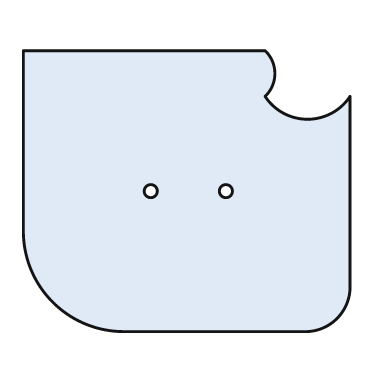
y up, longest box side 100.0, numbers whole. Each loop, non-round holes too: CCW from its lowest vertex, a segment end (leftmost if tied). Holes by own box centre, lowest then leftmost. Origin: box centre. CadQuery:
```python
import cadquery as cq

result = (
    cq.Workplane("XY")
    .moveTo(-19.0, -43.0)
    .lineTo(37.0, -43.0)
    .threePointArc((46.0, -39.0), (50.0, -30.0))
    .lineTo(50.0, 29.0)
    .threePointArc((37.0, 22.0), (24.0, 29.0))
    .threePointArc((27.0, 36.0), (24.0, 43.0))
    .lineTo(-50.0, 43.0)
    .lineTo(-50.0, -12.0)
    .threePointArc((-41.0, -34.0), (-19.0, -43.0))
    .close()
    .moveTo(-11.0, 0.0)
    .circle(2.0)
    .moveTo(12.0, 0.0)
    .circle(2.0)
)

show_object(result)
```